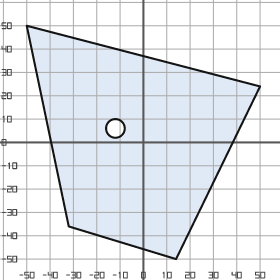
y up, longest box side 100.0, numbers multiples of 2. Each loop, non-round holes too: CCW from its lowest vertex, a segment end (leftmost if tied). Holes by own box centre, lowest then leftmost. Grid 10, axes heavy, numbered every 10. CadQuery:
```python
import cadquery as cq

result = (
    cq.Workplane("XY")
    .moveTo(14.0, -50.0)
    .lineTo(50.0, 24.0)
    .lineTo(-50.0, 50.0)
    .lineTo(-32.0, -36.0)
    .close()
    .moveTo(-12.0, 6.0)
    .circle(4.0)
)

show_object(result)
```